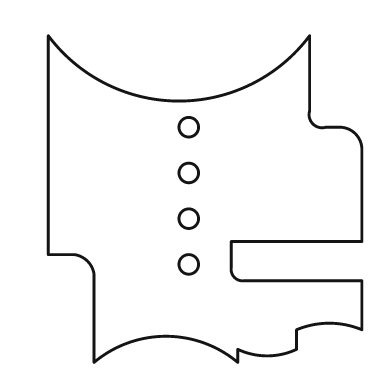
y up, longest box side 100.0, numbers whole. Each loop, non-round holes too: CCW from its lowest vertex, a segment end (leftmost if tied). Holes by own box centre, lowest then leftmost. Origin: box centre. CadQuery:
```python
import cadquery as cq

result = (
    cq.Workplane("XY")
    .moveTo(-34.0, -50.0)
    .threePointArc((-12.0, -42.0), (10.0, -50.0))
    .lineTo(10.0, -46.0)
    .threePointArc((19.0, -48.0), (28.0, -46.0))
    .lineTo(28.0, -40.0)
    .threePointArc((38.0, -38.0), (48.0, -40.0))
    .lineTo(48.0, -25.0)
    .lineTo(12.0, -25.0)
    .threePointArc((9.0, -24.0), (8.0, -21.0))
    .lineTo(8.0, -13.0)
    .lineTo(48.0, -13.0)
    .lineTo(48.0, 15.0)
    .threePointArc((46.0, 20.0), (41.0, 22.0))
    .lineTo(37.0, 22.0)
    .threePointArc((33.0, 23.0), (32.0, 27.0))
    .lineTo(32.0, 50.0)
    .threePointArc((-8.0, 30.0), (-48.0, 50.0))
    .lineTo(-48.0, -17.0)
    .lineTo(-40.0, -17.0)
    .threePointArc((-36.0, -19.0), (-34.0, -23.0))
    .close()
    .moveTo(-5.0, -20.0)
    .circle(3.0)
    .moveTo(-5.0, -6.0)
    .circle(3.0)
    .moveTo(-5.0, 8.0)
    .circle(3.0)
    .moveTo(-5.0, 22.0)
    .circle(3.0)
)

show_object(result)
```